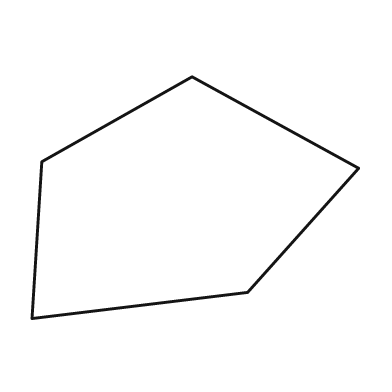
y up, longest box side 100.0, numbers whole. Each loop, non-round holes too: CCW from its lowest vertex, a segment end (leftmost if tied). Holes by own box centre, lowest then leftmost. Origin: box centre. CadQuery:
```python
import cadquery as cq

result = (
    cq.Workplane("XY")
    .moveTo(-50.0, -37.0)
    .lineTo(16.0, -29.0)
    .lineTo(50.0, 9.0)
    .lineTo(-1.0, 37.0)
    .lineTo(-47.0, 11.0)
    .close()
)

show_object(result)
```